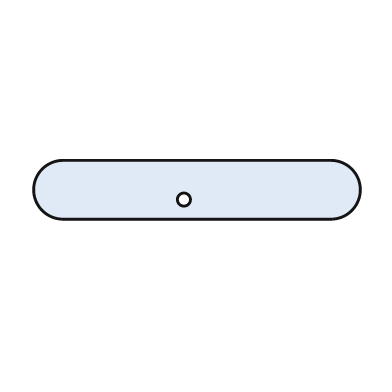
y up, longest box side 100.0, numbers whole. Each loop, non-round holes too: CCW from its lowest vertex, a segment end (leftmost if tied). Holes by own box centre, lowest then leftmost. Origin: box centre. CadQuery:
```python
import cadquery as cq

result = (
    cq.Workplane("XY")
    .moveTo(-41.0, -9.0)
    .lineTo(41.0, -9.0)
    .threePointArc((50.0, 0.0), (41.0, 9.0))
    .lineTo(-41.0, 9.0)
    .threePointArc((-50.0, 0.0), (-41.0, -9.0))
    .close()
    .moveTo(-4.0, -3.0)
    .circle(2.0)
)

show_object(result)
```